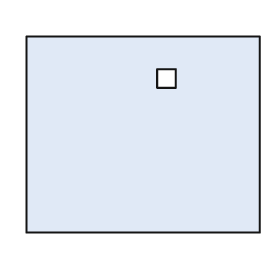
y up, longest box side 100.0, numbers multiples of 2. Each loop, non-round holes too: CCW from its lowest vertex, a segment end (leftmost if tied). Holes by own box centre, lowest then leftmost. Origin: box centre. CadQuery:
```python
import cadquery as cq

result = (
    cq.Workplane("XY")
    .moveTo(-50.0, -42.0)
    .lineTo(50.0, -42.0)
    .lineTo(50.0, 42.0)
    .lineTo(-50.0, 42.0)
    .close()
    .moveTo(6.0, 20.0)
    .lineTo(14.0, 20.0)
    .lineTo(14.0, 28.0)
    .lineTo(6.0, 28.0)
    .close()
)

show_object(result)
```